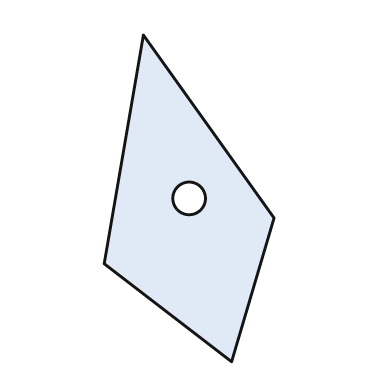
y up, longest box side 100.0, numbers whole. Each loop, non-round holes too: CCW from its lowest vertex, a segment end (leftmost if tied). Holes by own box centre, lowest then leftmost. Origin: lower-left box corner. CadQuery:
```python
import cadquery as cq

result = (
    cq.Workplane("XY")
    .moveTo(39.0, 0.0)
    .lineTo(52.0, 44.0)
    .lineTo(12.0, 100.0)
    .lineTo(0.0, 30.0)
    .close()
    .moveTo(26.0, 50.0)
    .circle(5.0)
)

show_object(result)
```